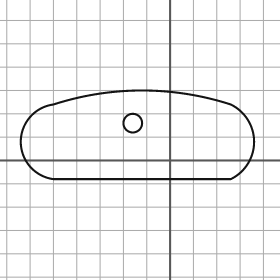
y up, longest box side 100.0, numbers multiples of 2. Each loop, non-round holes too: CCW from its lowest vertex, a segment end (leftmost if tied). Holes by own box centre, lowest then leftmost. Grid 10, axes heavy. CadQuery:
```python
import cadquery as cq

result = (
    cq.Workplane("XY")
    .moveTo(-50.0, -8.0)
    .lineTo(26.0, -8.0)
    .threePointArc((36.0, 8.0), (26.0, 24.0))
    .threePointArc((-12.0, 30.0), (-50.0, 24.0))
    .threePointArc((-64.0, 8.0), (-50.0, -8.0))
    .close()
    .moveTo(-16.0, 16.0)
    .circle(4.0)
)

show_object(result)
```